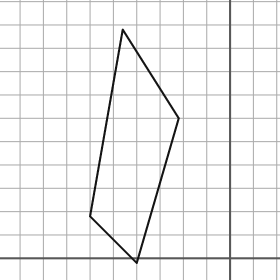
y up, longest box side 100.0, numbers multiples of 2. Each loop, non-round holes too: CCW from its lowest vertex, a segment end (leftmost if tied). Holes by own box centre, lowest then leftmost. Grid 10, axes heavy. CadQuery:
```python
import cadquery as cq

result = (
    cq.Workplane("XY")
    .moveTo(-40.0, -2.0)
    .lineTo(-22.0, 60.0)
    .lineTo(-46.0, 98.0)
    .lineTo(-60.0, 18.0)
    .close()
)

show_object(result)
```